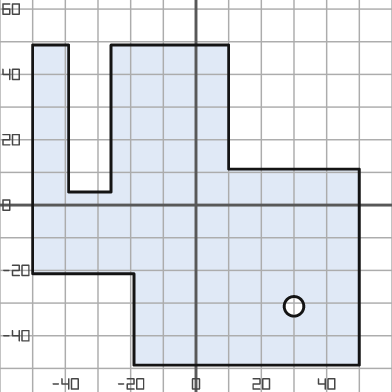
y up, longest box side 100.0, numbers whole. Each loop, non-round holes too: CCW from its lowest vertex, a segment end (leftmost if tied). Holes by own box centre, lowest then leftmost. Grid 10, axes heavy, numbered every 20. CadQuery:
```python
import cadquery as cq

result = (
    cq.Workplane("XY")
    .moveTo(-19.0, -49.0)
    .lineTo(50.0, -49.0)
    .lineTo(50.0, 11.0)
    .lineTo(10.0, 11.0)
    .lineTo(10.0, 49.0)
    .lineTo(-26.0, 49.0)
    .lineTo(-26.0, 4.0)
    .lineTo(-39.0, 4.0)
    .lineTo(-39.0, 49.0)
    .lineTo(-50.0, 49.0)
    .lineTo(-50.0, -21.0)
    .lineTo(-19.0, -21.0)
    .close()
    .moveTo(30.0, -31.0)
    .circle(3.0)
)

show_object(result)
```